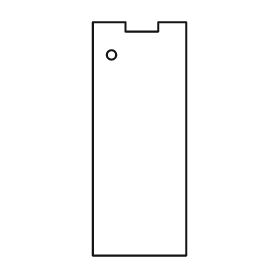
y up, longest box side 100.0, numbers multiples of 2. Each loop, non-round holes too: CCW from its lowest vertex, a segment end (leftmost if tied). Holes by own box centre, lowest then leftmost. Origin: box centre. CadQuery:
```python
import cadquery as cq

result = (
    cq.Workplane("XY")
    .moveTo(-20.0, -50.0)
    .lineTo(20.0, -50.0)
    .lineTo(20.0, 50.0)
    .lineTo(8.0, 50.0)
    .lineTo(8.0, 46.0)
    .lineTo(-6.0, 46.0)
    .lineTo(-6.0, 50.0)
    .lineTo(-20.0, 50.0)
    .close()
    .moveTo(-12.0, 36.0)
    .circle(2.0)
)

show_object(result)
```